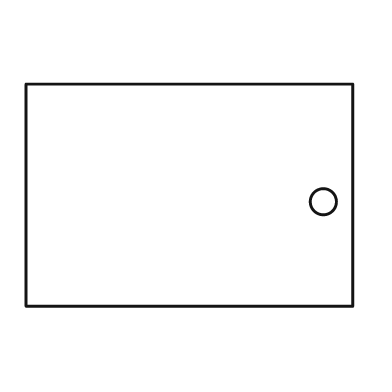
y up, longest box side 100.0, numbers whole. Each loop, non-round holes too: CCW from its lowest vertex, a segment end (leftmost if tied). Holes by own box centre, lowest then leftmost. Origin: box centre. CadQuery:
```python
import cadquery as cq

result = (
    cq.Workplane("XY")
    .moveTo(-50.0, -34.0)
    .lineTo(50.0, -34.0)
    .lineTo(50.0, 34.0)
    .lineTo(-50.0, 34.0)
    .close()
    .moveTo(41.0, -2.0)
    .circle(4.0)
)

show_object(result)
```